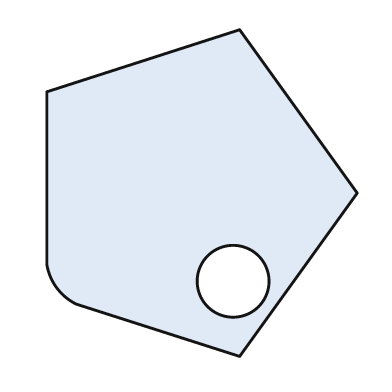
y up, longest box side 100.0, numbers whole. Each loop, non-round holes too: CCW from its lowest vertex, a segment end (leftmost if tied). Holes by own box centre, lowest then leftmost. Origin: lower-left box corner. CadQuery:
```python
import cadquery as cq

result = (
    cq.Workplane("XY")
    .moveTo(59.0, 0.0)
    .lineTo(95.0, 50.0)
    .lineTo(59.0, 100.0)
    .lineTo(0.0, 81.0)
    .lineTo(0.0, 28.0)
    .threePointArc((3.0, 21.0), (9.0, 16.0))
    .close()
    .moveTo(57.0, 23.0)
    .circle(11.0)
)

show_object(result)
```